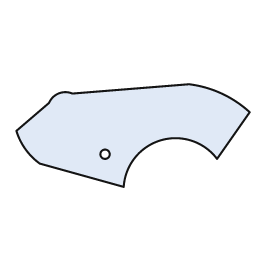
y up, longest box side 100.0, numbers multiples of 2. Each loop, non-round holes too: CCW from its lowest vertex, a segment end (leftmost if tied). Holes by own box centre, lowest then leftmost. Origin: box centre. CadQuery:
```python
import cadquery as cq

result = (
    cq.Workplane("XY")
    .moveTo(-4.0, -22.0)
    .threePointArc((12.0, -2.0), (36.0, -10.0))
    .lineTo(50.0, 10.0)
    .threePointArc((38.0, 18.0), (24.0, 22.0))
    .lineTo(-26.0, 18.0)
    .threePointArc((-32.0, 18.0), (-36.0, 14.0))
    .lineTo(-50.0, 2.0)
    .threePointArc((-46.0, -6.0), (-40.0, -12.0))
    .close()
    .moveTo(-12.0, -8.0)
    .circle(2.0)
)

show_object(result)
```